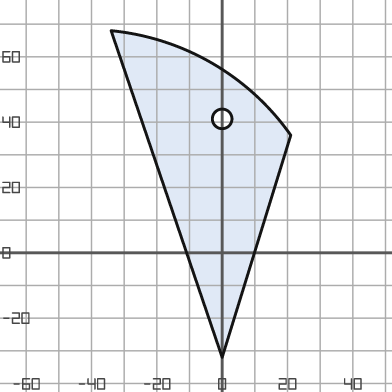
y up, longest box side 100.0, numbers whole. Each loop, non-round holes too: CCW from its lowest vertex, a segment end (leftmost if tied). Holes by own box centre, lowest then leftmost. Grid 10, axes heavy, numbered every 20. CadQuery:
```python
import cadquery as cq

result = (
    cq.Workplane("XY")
    .moveTo(0.0, -32.0)
    .lineTo(21.0, 36.0)
    .threePointArc((-3.0, 58.0), (-34.0, 68.0))
    .close()
    .moveTo(0.0, 41.0)
    .circle(3.0)
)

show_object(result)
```